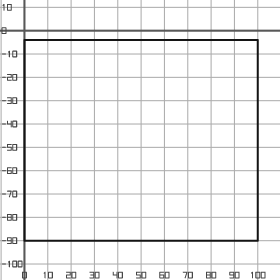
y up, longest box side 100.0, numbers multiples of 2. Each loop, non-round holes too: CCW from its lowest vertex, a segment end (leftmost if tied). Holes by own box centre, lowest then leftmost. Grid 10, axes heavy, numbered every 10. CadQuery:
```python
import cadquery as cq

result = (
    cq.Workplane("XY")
    .moveTo(0.0, -90.0)
    .lineTo(100.0, -90.0)
    .lineTo(100.0, -4.0)
    .lineTo(0.0, -4.0)
    .close()
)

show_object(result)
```